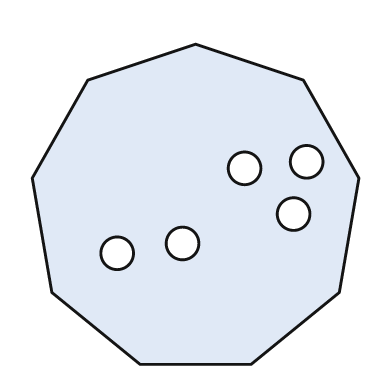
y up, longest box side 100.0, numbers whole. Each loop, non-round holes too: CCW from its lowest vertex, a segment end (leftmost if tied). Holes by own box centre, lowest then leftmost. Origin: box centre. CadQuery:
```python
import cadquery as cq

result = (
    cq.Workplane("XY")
    .moveTo(-17.0, -49.0)
    .lineTo(17.0, -49.0)
    .lineTo(44.0, -27.0)
    .lineTo(50.0, 8.0)
    .lineTo(33.0, 38.0)
    .lineTo(0.0, 49.0)
    .lineTo(-33.0, 38.0)
    .lineTo(-50.0, 8.0)
    .lineTo(-44.0, -27.0)
    .close()
    .moveTo(-24.0, -15.0)
    .circle(5.0)
    .moveTo(-4.0, -12.0)
    .circle(5.0)
    .moveTo(30.0, -3.0)
    .circle(5.0)
    .moveTo(15.0, 11.0)
    .circle(5.0)
    .moveTo(34.0, 13.0)
    .circle(5.0)
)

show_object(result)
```